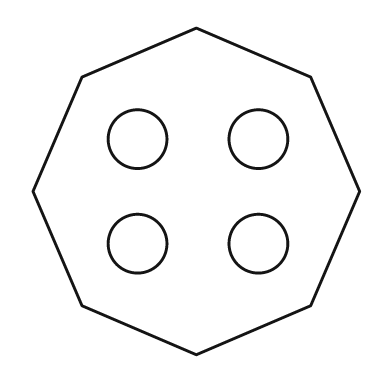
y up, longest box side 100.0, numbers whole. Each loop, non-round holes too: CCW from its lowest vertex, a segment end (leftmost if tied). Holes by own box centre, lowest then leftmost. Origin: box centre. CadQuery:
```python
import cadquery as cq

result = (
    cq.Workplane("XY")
    .moveTo(0.0, -50.0)
    .lineTo(35.0, -35.0)
    .lineTo(50.0, 0.0)
    .lineTo(35.0, 35.0)
    .lineTo(0.0, 50.0)
    .lineTo(-35.0, 35.0)
    .lineTo(-50.0, 0.0)
    .lineTo(-35.0, -35.0)
    .close()
    .moveTo(-18.0, -16.0)
    .circle(9.0)
    .moveTo(19.0, -16.0)
    .circle(9.0)
    .moveTo(-18.0, 16.0)
    .circle(9.0)
    .moveTo(19.0, 16.0)
    .circle(9.0)
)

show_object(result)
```